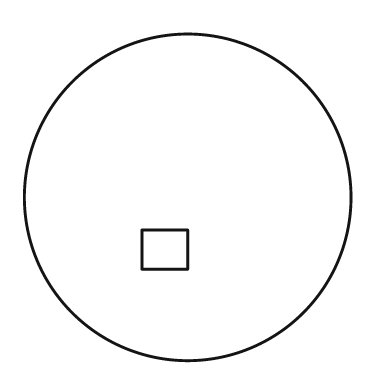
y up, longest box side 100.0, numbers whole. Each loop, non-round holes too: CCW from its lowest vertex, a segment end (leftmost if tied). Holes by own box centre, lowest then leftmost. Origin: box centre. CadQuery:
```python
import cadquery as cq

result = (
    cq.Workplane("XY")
    .moveTo(0.0, 0.0)
    .circle(50.0)
    .moveTo(-14.0, -22.0)
    .lineTo(0.0, -22.0)
    .lineTo(0.0, -10.0)
    .lineTo(-14.0, -10.0)
    .close()
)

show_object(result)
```